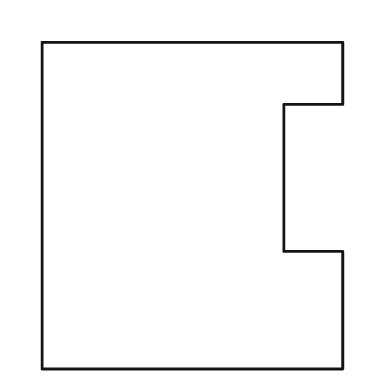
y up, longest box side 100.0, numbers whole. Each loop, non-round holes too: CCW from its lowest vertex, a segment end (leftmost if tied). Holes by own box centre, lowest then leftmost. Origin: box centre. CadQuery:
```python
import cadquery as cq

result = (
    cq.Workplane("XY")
    .moveTo(-46.0, -50.0)
    .lineTo(46.0, -50.0)
    .lineTo(46.0, -14.0)
    .lineTo(28.0, -14.0)
    .lineTo(28.0, 31.0)
    .lineTo(46.0, 31.0)
    .lineTo(46.0, 50.0)
    .lineTo(-46.0, 50.0)
    .close()
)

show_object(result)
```